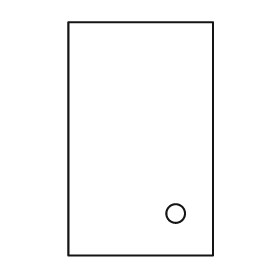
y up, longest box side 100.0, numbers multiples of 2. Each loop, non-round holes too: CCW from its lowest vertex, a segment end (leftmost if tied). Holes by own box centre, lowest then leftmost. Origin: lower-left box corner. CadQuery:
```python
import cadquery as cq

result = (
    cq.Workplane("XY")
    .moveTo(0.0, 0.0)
    .lineTo(62.0, 0.0)
    .lineTo(62.0, 100.0)
    .lineTo(0.0, 100.0)
    .close()
    .moveTo(46.0, 18.0)
    .circle(4.0)
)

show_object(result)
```